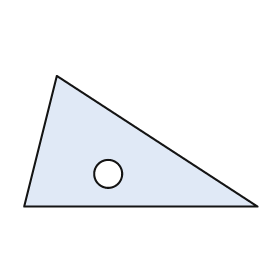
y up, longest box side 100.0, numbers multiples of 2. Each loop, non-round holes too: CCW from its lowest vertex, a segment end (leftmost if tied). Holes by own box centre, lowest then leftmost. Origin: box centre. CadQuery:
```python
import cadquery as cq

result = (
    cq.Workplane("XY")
    .moveTo(-50.0, -28.0)
    .lineTo(50.0, -28.0)
    .lineTo(-36.0, 28.0)
    .close()
    .moveTo(-14.0, -14.0)
    .circle(6.0)
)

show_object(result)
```